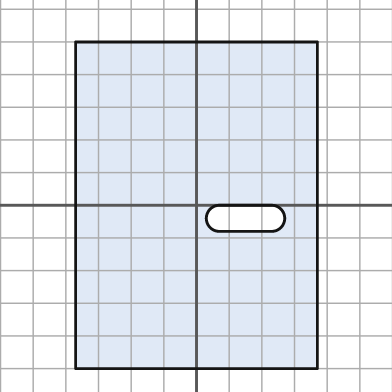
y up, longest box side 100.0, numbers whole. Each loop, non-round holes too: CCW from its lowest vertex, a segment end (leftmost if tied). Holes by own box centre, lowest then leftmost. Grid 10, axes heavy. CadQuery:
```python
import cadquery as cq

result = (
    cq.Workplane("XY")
    .moveTo(-37.0, -50.0)
    .lineTo(37.0, -50.0)
    .lineTo(37.0, 50.0)
    .lineTo(-37.0, 50.0)
    .close()
    .moveTo(7.0, -8.0)
    .lineTo(23.0, -8.0)
    .threePointArc((27.0, -4.0), (23.0, 0.0))
    .lineTo(7.0, 0.0)
    .threePointArc((3.0, -4.0), (7.0, -8.0))
    .close()
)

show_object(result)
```